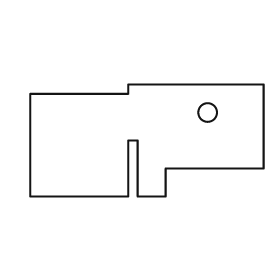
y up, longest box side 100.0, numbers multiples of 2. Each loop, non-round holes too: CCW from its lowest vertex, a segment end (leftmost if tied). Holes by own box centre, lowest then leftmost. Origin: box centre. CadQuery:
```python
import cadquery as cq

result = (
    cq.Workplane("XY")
    .moveTo(-50.0, -24.0)
    .lineTo(-8.0, -24.0)
    .lineTo(-8.0, 0.0)
    .lineTo(-4.0, 0.0)
    .lineTo(-4.0, -24.0)
    .lineTo(8.0, -24.0)
    .lineTo(8.0, -12.0)
    .lineTo(50.0, -12.0)
    .lineTo(50.0, 24.0)
    .lineTo(-8.0, 24.0)
    .lineTo(-8.0, 20.0)
    .lineTo(-50.0, 20.0)
    .close()
    .moveTo(26.0, 12.0)
    .circle(4.0)
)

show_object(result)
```